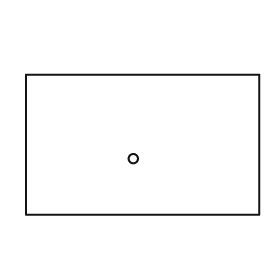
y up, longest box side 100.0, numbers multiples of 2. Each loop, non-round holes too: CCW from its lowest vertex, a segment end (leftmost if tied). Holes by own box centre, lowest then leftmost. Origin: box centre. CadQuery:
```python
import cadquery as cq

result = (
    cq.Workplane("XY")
    .moveTo(-50.0, -30.0)
    .lineTo(50.0, -30.0)
    .lineTo(50.0, 30.0)
    .lineTo(-50.0, 30.0)
    .close()
    .moveTo(-4.0, -6.0)
    .circle(2.0)
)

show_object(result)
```